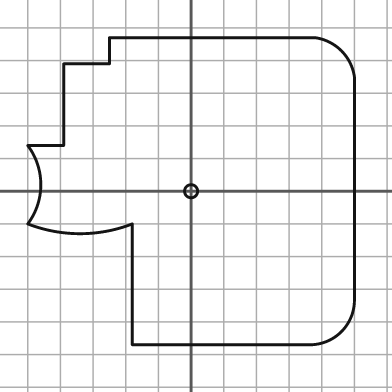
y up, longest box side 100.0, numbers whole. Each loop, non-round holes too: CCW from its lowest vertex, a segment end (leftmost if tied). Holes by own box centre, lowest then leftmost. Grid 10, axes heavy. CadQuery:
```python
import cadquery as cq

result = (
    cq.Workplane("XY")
    .moveTo(-18.0, -47.0)
    .lineTo(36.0, -47.0)
    .threePointArc((46.0, -43.0), (50.0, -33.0))
    .lineTo(50.0, 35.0)
    .threePointArc((46.0, 43.0), (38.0, 47.0))
    .lineTo(-25.0, 47.0)
    .lineTo(-25.0, 39.0)
    .lineTo(-39.0, 39.0)
    .lineTo(-39.0, 14.0)
    .lineTo(-50.0, 14.0)
    .threePointArc((-46.0, 2.0), (-50.0, -10.0))
    .threePointArc((-34.0, -13.0), (-18.0, -10.0))
    .close()
    .moveTo(0.0, 0.0)
    .circle(2.0)
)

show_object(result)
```